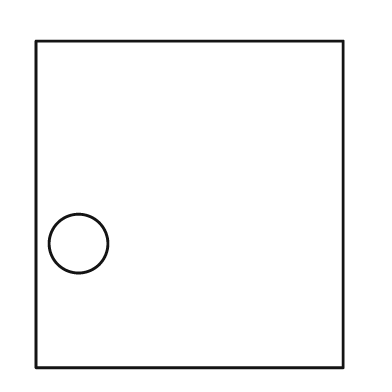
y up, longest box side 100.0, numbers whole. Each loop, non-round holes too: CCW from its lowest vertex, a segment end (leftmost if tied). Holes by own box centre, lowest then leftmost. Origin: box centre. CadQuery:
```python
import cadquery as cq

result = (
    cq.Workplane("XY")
    .moveTo(-47.0, -50.0)
    .lineTo(47.0, -50.0)
    .lineTo(47.0, 50.0)
    .lineTo(-47.0, 50.0)
    .close()
    .moveTo(-34.0, -12.0)
    .circle(9.0)
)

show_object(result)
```